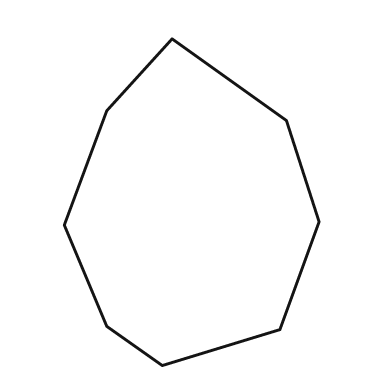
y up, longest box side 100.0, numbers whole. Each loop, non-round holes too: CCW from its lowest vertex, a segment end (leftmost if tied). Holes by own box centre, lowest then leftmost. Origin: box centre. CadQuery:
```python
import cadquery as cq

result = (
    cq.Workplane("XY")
    .moveTo(-9.0, -50.0)
    .lineTo(27.0, -39.0)
    .lineTo(39.0, -6.0)
    .lineTo(29.0, 25.0)
    .lineTo(-6.0, 50.0)
    .lineTo(-26.0, 28.0)
    .lineTo(-39.0, -7.0)
    .lineTo(-26.0, -38.0)
    .close()
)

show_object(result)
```